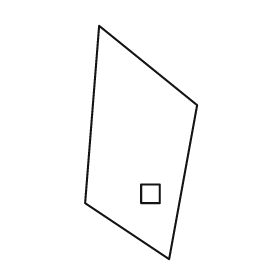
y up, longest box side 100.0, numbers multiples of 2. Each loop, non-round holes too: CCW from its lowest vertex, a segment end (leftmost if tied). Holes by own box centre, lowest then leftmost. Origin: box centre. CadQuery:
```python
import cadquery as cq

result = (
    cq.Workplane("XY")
    .moveTo(12.0, -50.0)
    .lineTo(24.0, 16.0)
    .lineTo(-18.0, 50.0)
    .lineTo(-24.0, -26.0)
    .close()
    .moveTo(0.0, -26.0)
    .lineTo(8.0, -26.0)
    .lineTo(8.0, -18.0)
    .lineTo(0.0, -18.0)
    .close()
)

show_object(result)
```